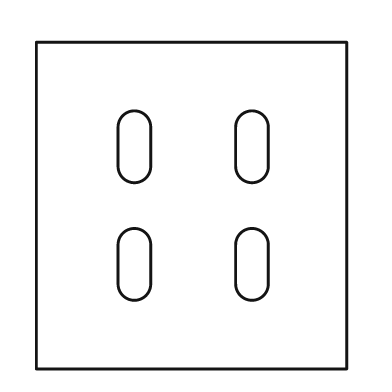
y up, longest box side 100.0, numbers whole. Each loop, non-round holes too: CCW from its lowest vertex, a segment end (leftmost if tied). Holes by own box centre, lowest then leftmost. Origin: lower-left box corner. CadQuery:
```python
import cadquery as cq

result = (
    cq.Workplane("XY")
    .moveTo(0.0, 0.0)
    .lineTo(95.0, 0.0)
    .lineTo(95.0, 100.0)
    .lineTo(0.0, 100.0)
    .close()
    .moveTo(25.0, 26.0)
    .threePointArc((30.0, 21.0), (35.0, 26.0))
    .lineTo(35.0, 38.0)
    .threePointArc((30.0, 43.0), (25.0, 38.0))
    .close()
    .moveTo(61.0, 26.0)
    .threePointArc((66.0, 21.0), (71.0, 26.0))
    .lineTo(71.0, 38.0)
    .threePointArc((66.0, 43.0), (61.0, 38.0))
    .close()
    .moveTo(25.0, 62.0)
    .threePointArc((30.0, 57.0), (35.0, 62.0))
    .lineTo(35.0, 74.0)
    .threePointArc((30.0, 79.0), (25.0, 74.0))
    .close()
    .moveTo(61.0, 62.0)
    .threePointArc((66.0, 57.0), (71.0, 62.0))
    .lineTo(71.0, 74.0)
    .threePointArc((66.0, 79.0), (61.0, 74.0))
    .close()
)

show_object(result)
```